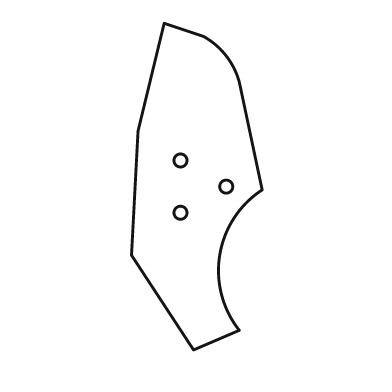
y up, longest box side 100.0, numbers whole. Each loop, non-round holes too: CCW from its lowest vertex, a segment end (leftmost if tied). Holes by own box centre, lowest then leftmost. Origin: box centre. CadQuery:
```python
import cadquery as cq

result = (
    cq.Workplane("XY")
    .moveTo(-1.0, -50.0)
    .lineTo(13.0, -44.0)
    .threePointArc((7.0, -21.0), (20.0, -1.0))
    .lineTo(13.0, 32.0)
    .threePointArc((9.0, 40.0), (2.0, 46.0))
    .lineTo(-10.0, 50.0)
    .lineTo(-18.0, 17.0)
    .lineTo(-20.0, -21.0)
    .close()
    .moveTo(-5.0, -8.0)
    .circle(2.0)
    .moveTo(9.0, 0.0)
    .circle(2.0)
    .moveTo(-5.0, 8.0)
    .circle(2.0)
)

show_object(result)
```